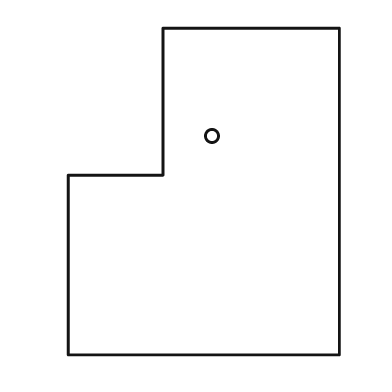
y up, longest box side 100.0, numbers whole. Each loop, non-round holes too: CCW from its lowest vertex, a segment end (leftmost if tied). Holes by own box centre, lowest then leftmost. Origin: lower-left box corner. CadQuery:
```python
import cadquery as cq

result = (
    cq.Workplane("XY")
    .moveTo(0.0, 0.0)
    .lineTo(83.0, 0.0)
    .lineTo(83.0, 100.0)
    .lineTo(29.0, 100.0)
    .lineTo(29.0, 55.0)
    .lineTo(0.0, 55.0)
    .close()
    .moveTo(44.0, 67.0)
    .circle(2.0)
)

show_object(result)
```